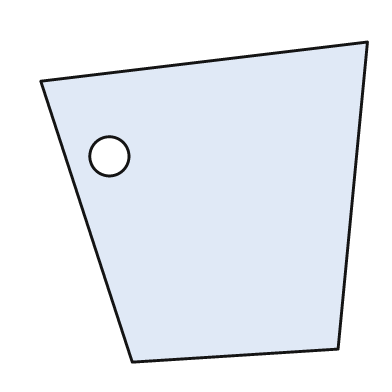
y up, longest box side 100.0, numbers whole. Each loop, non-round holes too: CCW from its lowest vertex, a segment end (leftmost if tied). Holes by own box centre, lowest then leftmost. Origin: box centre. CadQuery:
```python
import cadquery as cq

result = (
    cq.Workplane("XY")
    .moveTo(-22.0, -49.0)
    .lineTo(41.0, -45.0)
    .lineTo(50.0, 49.0)
    .lineTo(-50.0, 37.0)
    .close()
    .moveTo(-29.0, 14.0)
    .circle(6.0)
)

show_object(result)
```